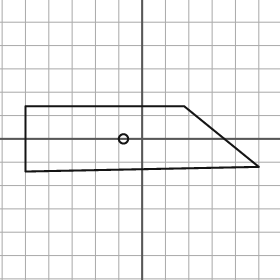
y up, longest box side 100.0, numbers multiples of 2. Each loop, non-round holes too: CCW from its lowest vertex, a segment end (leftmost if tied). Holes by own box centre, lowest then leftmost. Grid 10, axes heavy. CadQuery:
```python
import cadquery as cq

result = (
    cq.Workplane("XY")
    .moveTo(-50.0, -14.0)
    .lineTo(50.0, -12.0)
    .lineTo(18.0, 14.0)
    .lineTo(-50.0, 14.0)
    .close()
    .moveTo(-8.0, 0.0)
    .circle(2.0)
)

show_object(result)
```